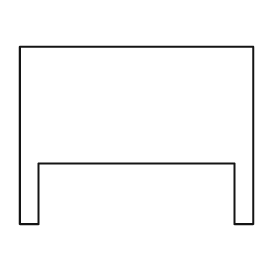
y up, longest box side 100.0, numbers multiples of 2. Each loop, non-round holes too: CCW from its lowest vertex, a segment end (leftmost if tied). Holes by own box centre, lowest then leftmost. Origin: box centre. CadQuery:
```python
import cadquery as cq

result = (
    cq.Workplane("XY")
    .moveTo(-50.0, -38.0)
    .lineTo(-42.0, -38.0)
    .lineTo(-42.0, -12.0)
    .lineTo(42.0, -12.0)
    .lineTo(42.0, -38.0)
    .lineTo(50.0, -38.0)
    .lineTo(50.0, 38.0)
    .lineTo(-50.0, 38.0)
    .close()
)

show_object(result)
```